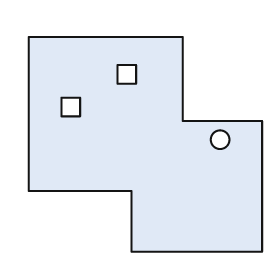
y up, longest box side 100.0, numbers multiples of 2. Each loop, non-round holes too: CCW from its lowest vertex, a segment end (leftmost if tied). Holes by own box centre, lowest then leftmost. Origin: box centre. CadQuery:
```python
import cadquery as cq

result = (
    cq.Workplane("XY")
    .moveTo(-6.0, -46.0)
    .lineTo(50.0, -46.0)
    .lineTo(50.0, 10.0)
    .lineTo(16.0, 10.0)
    .lineTo(16.0, 46.0)
    .lineTo(-50.0, 46.0)
    .lineTo(-50.0, -20.0)
    .lineTo(-6.0, -20.0)
    .close()
    .moveTo(32.0, 2.0)
    .circle(4.0)
    .moveTo(-36.0, 12.0)
    .lineTo(-28.0, 12.0)
    .lineTo(-28.0, 20.0)
    .lineTo(-36.0, 20.0)
    .close()
    .moveTo(-12.0, 26.0)
    .lineTo(-4.0, 26.0)
    .lineTo(-4.0, 34.0)
    .lineTo(-12.0, 34.0)
    .close()
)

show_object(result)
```